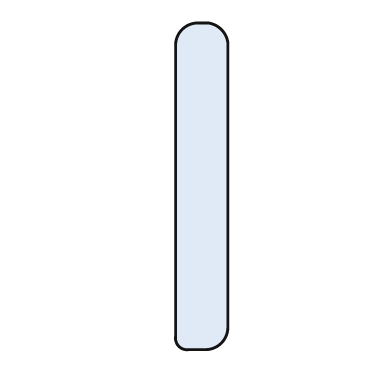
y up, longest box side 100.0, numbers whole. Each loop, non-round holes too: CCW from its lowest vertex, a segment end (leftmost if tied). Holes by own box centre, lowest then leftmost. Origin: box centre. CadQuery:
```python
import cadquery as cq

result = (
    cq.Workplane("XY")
    .moveTo(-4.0, -50.0)
    .lineTo(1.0, -50.0)
    .threePointArc((6.0, -48.0), (8.0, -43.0))
    .lineTo(8.0, 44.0)
    .threePointArc((6.0, 48.0), (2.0, 50.0))
    .lineTo(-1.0, 50.0)
    .threePointArc((-6.0, 48.0), (-8.0, 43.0))
    .lineTo(-8.0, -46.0)
    .threePointArc((-7.0, -49.0), (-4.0, -50.0))
    .close()
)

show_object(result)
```